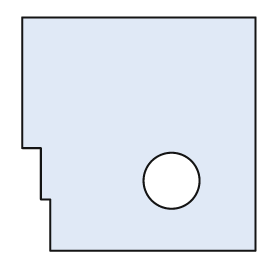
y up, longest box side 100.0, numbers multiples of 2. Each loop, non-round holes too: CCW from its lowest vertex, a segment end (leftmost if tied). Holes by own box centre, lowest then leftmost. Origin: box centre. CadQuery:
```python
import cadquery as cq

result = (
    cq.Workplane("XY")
    .moveTo(-38.0, -50.0)
    .lineTo(50.0, -50.0)
    .lineTo(50.0, 50.0)
    .lineTo(-50.0, 50.0)
    .lineTo(-50.0, -6.0)
    .lineTo(-42.0, -6.0)
    .lineTo(-42.0, -28.0)
    .lineTo(-38.0, -28.0)
    .close()
    .moveTo(14.0, -20.0)
    .circle(12.0)
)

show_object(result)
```